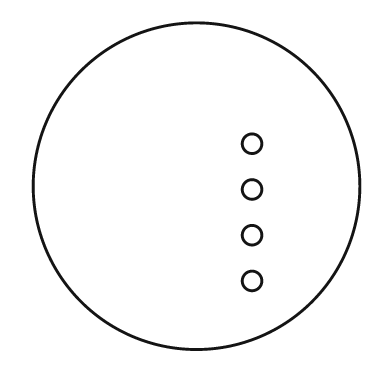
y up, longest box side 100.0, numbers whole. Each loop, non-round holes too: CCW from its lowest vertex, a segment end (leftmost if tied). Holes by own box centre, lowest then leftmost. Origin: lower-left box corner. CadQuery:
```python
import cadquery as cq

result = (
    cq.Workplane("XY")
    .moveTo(50.0, 50.0)
    .circle(50.0)
    .moveTo(67.0, 21.0)
    .circle(3.0)
    .moveTo(67.0, 35.0)
    .circle(3.0)
    .moveTo(67.0, 49.0)
    .circle(3.0)
    .moveTo(67.0, 63.0)
    .circle(3.0)
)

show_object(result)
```